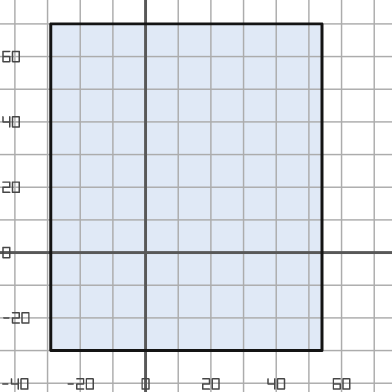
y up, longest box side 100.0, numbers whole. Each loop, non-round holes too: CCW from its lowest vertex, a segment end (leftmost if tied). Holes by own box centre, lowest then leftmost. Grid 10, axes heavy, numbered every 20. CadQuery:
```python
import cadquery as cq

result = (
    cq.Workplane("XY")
    .moveTo(-29.0, -30.0)
    .lineTo(54.0, -30.0)
    .lineTo(54.0, 70.0)
    .lineTo(-29.0, 70.0)
    .close()
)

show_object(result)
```